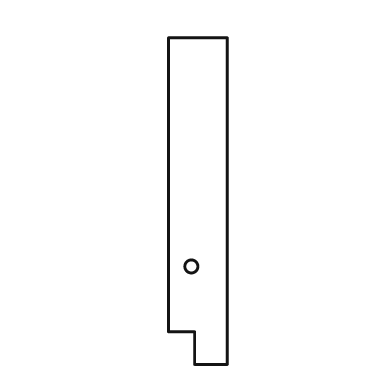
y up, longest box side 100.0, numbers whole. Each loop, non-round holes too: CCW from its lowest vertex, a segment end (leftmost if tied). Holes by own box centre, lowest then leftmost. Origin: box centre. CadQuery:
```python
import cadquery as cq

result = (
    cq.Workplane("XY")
    .moveTo(-1.0, -50.0)
    .lineTo(9.0, -50.0)
    .lineTo(9.0, 50.0)
    .lineTo(-9.0, 50.0)
    .lineTo(-9.0, -40.0)
    .lineTo(-1.0, -40.0)
    .close()
    .moveTo(-2.0, -20.0)
    .circle(2.0)
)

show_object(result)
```